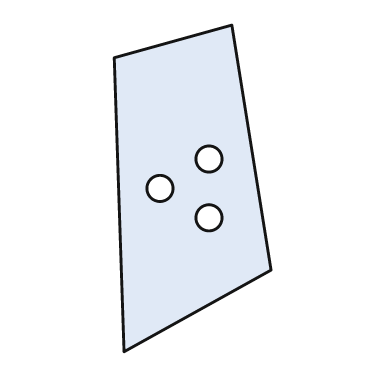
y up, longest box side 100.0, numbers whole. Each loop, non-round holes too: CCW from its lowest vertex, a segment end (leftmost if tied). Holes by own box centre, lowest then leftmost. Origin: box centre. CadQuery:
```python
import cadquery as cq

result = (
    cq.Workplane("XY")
    .moveTo(-21.0, -50.0)
    .lineTo(24.0, -25.0)
    .lineTo(12.0, 50.0)
    .lineTo(-24.0, 40.0)
    .close()
    .moveTo(5.0, -9.0)
    .circle(4.0)
    .moveTo(-10.0, 0.0)
    .circle(4.0)
    .moveTo(5.0, 9.0)
    .circle(4.0)
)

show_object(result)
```